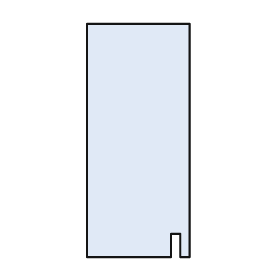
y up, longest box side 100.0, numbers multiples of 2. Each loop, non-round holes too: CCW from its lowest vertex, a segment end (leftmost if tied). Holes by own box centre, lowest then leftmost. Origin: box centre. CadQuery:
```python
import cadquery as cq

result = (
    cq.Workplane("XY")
    .moveTo(-22.0, -50.0)
    .lineTo(14.0, -50.0)
    .lineTo(14.0, -40.0)
    .lineTo(18.0, -40.0)
    .lineTo(18.0, -50.0)
    .lineTo(22.0, -50.0)
    .lineTo(22.0, 50.0)
    .lineTo(-22.0, 50.0)
    .close()
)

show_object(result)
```